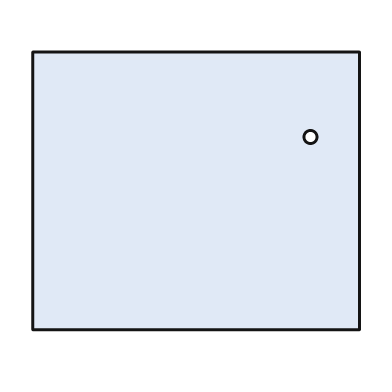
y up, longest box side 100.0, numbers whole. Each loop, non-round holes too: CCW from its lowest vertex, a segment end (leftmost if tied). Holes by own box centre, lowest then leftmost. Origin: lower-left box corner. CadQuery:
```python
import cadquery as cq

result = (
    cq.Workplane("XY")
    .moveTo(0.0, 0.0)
    .lineTo(100.0, 0.0)
    .lineTo(100.0, 85.0)
    .lineTo(0.0, 85.0)
    .close()
    .moveTo(85.0, 59.0)
    .circle(2.0)
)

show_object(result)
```